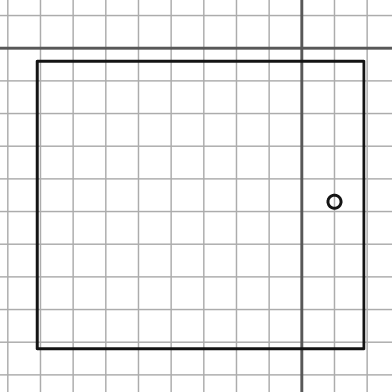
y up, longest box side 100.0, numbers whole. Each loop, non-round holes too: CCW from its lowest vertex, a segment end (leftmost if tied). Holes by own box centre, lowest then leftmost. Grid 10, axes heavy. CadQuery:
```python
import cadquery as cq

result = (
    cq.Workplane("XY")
    .moveTo(-81.0, -92.0)
    .lineTo(19.0, -92.0)
    .lineTo(19.0, -4.0)
    .lineTo(-81.0, -4.0)
    .close()
    .moveTo(10.0, -47.0)
    .circle(2.0)
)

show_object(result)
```